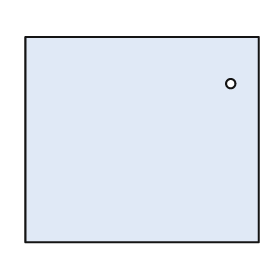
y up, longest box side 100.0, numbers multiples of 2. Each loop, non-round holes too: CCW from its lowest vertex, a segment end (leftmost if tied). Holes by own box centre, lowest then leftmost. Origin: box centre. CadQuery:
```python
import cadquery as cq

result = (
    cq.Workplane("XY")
    .moveTo(-50.0, -44.0)
    .lineTo(50.0, -44.0)
    .lineTo(50.0, 44.0)
    .lineTo(-50.0, 44.0)
    .close()
    .moveTo(38.0, 24.0)
    .circle(2.0)
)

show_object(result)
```